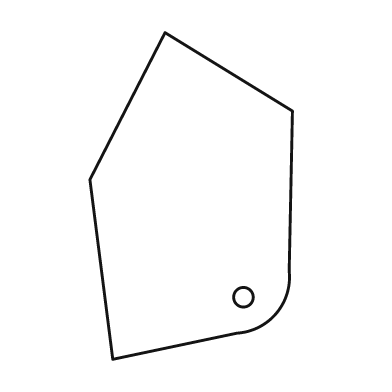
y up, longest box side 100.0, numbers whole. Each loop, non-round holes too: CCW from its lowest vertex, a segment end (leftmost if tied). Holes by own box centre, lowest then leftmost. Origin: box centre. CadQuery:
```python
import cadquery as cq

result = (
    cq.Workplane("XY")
    .moveTo(-24.0, -50.0)
    .lineTo(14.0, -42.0)
    .threePointArc((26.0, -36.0), (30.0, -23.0))
    .lineTo(31.0, 26.0)
    .lineTo(-8.0, 50.0)
    .lineTo(-31.0, 5.0)
    .close()
    .moveTo(16.0, -31.0)
    .circle(3.0)
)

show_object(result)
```